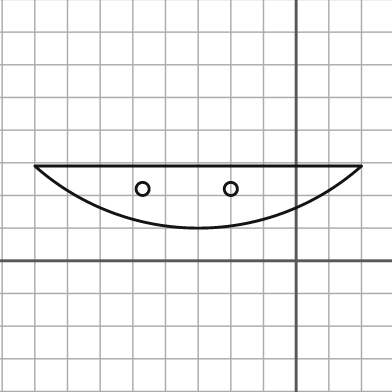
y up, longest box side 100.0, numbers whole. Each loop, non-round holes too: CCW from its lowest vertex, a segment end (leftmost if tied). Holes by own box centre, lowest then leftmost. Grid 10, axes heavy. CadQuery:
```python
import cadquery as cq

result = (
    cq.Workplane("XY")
    .moveTo(-80.0, 29.0)
    .threePointArc((-30.0, 10.0), (20.0, 29.0))
    .close()
    .moveTo(-47.0, 22.0)
    .circle(2.0)
    .moveTo(-20.0, 22.0)
    .circle(2.0)
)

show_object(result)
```